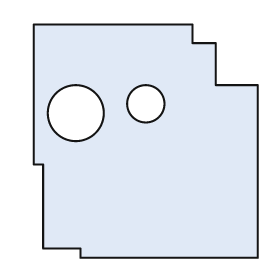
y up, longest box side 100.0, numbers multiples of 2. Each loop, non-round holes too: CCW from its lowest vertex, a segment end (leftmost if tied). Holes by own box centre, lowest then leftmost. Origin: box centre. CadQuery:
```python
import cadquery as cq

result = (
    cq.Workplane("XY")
    .moveTo(-28.0, -50.0)
    .lineTo(48.0, -50.0)
    .lineTo(48.0, 24.0)
    .lineTo(30.0, 24.0)
    .lineTo(30.0, 42.0)
    .lineTo(20.0, 42.0)
    .lineTo(20.0, 50.0)
    .lineTo(-48.0, 50.0)
    .lineTo(-48.0, -10.0)
    .lineTo(-44.0, -10.0)
    .lineTo(-44.0, -46.0)
    .lineTo(-28.0, -46.0)
    .close()
    .moveTo(-30.0, 12.0)
    .circle(12.0)
    .moveTo(0.0, 16.0)
    .circle(8.0)
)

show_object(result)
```